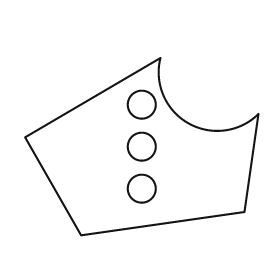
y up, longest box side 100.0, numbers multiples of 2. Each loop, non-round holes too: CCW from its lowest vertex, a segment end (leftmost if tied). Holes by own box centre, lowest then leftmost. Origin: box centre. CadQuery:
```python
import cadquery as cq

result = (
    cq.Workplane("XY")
    .moveTo(-26.0, -38.0)
    .lineTo(44.0, -28.0)
    .lineTo(50.0, 14.0)
    .threePointArc((20.0, 10.0), (8.0, 38.0))
    .lineTo(-50.0, 4.0)
    .close()
    .moveTo(0.0, -18.0)
    .circle(6.0)
    .moveTo(0.0, 0.0)
    .circle(6.0)
    .moveTo(0.0, 18.0)
    .circle(6.0)
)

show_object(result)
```